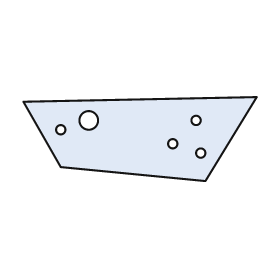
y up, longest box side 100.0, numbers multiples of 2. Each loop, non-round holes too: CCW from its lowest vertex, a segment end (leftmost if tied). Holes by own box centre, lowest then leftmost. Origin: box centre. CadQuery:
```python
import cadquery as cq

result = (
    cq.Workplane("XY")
    .moveTo(28.0, -18.0)
    .lineTo(50.0, 18.0)
    .lineTo(-50.0, 16.0)
    .lineTo(-34.0, -12.0)
    .close()
    .moveTo(26.0, -6.0)
    .circle(2.0)
    .moveTo(14.0, -2.0)
    .circle(2.0)
    .moveTo(-34.0, 4.0)
    .circle(2.0)
    .moveTo(-22.0, 8.0)
    .circle(4.0)
    .moveTo(24.0, 8.0)
    .circle(2.0)
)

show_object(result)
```